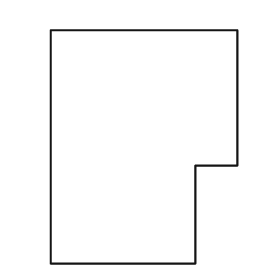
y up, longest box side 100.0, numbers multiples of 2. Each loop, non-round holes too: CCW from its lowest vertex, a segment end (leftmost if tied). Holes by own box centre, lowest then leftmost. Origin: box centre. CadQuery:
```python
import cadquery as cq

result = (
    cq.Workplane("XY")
    .moveTo(-40.0, -50.0)
    .lineTo(22.0, -50.0)
    .lineTo(22.0, -8.0)
    .lineTo(40.0, -8.0)
    .lineTo(40.0, 50.0)
    .lineTo(-40.0, 50.0)
    .close()
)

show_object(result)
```